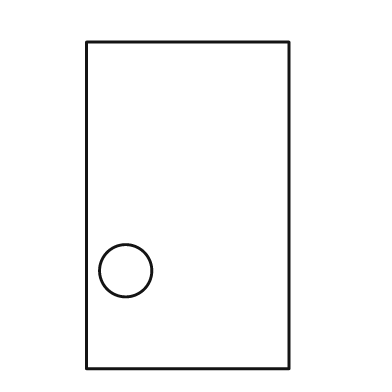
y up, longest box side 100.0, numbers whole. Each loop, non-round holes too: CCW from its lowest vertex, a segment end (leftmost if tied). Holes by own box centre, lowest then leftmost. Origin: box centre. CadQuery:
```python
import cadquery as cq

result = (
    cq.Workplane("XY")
    .moveTo(-31.0, -50.0)
    .lineTo(31.0, -50.0)
    .lineTo(31.0, 50.0)
    .lineTo(-31.0, 50.0)
    .close()
    .moveTo(-19.0, -20.0)
    .circle(8.0)
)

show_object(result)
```